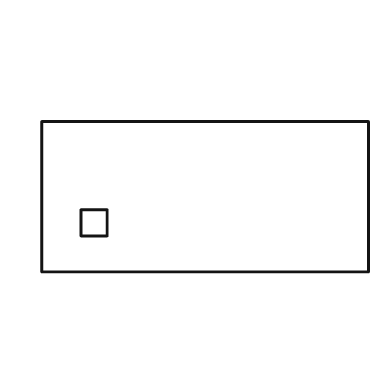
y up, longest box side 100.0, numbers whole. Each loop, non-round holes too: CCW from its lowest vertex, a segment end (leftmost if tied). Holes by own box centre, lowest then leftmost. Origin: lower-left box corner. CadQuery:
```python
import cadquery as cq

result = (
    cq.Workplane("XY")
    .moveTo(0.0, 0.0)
    .lineTo(100.0, 0.0)
    .lineTo(100.0, 46.0)
    .lineTo(0.0, 46.0)
    .close()
    .moveTo(12.0, 11.0)
    .lineTo(20.0, 11.0)
    .lineTo(20.0, 19.0)
    .lineTo(12.0, 19.0)
    .close()
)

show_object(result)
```